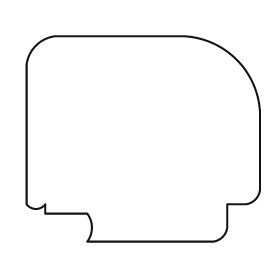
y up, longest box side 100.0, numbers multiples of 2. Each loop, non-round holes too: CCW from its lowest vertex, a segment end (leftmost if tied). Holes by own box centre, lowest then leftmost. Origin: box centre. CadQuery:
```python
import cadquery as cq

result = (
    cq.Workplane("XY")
    .moveTo(-24.0, -44.0)
    .lineTo(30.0, -44.0)
    .threePointArc((34.0, -42.0), (36.0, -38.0))
    .lineTo(36.0, -28.0)
    .lineTo(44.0, -28.0)
    .threePointArc((48.0, -26.0), (50.0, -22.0))
    .lineTo(50.0, 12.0)
    .threePointArc((40.0, 34.0), (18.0, 44.0))
    .lineTo(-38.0, 44.0)
    .threePointArc((-46.0, 40.0), (-50.0, 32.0))
    .lineTo(-50.0, -28.0)
    .threePointArc((-46.0, -30.0), (-42.0, -28.0))
    .lineTo(-42.0, -32.0)
    .lineTo(-24.0, -32.0)
    .threePointArc((-22.0, -38.0), (-24.0, -44.0))
    .close()
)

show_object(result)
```